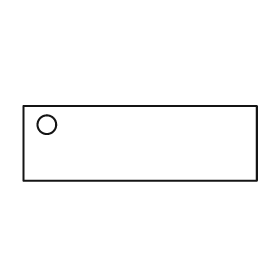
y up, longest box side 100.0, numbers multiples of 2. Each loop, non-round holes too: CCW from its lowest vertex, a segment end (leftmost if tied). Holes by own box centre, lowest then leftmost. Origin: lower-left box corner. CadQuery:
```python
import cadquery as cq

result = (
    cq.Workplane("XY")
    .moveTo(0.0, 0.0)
    .lineTo(100.0, 0.0)
    .lineTo(100.0, 32.0)
    .lineTo(0.0, 32.0)
    .close()
    .moveTo(10.0, 24.0)
    .circle(4.0)
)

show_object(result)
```